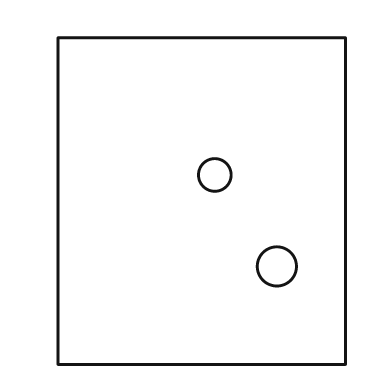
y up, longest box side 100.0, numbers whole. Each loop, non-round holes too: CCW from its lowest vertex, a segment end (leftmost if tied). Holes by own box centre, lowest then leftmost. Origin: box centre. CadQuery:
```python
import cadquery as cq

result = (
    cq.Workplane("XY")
    .moveTo(-44.0, -50.0)
    .lineTo(44.0, -50.0)
    .lineTo(44.0, 50.0)
    .lineTo(-44.0, 50.0)
    .close()
    .moveTo(23.0, -20.0)
    .circle(6.0)
    .moveTo(4.0, 8.0)
    .circle(5.0)
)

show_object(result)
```